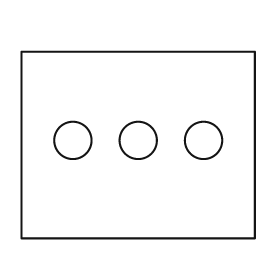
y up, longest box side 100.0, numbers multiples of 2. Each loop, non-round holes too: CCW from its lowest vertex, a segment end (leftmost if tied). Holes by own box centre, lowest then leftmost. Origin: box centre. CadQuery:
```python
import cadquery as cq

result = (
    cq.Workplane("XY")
    .moveTo(-50.0, -40.0)
    .lineTo(50.0, -40.0)
    .lineTo(50.0, 40.0)
    .lineTo(-50.0, 40.0)
    .close()
    .moveTo(-28.0, 2.0)
    .circle(8.0)
    .moveTo(0.0, 2.0)
    .circle(8.0)
    .moveTo(28.0, 2.0)
    .circle(8.0)
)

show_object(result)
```